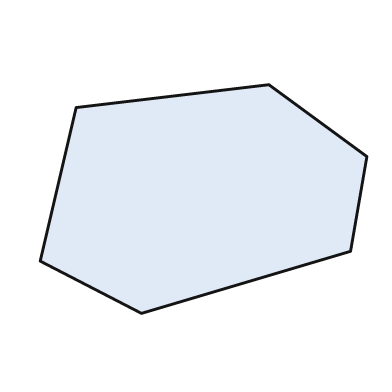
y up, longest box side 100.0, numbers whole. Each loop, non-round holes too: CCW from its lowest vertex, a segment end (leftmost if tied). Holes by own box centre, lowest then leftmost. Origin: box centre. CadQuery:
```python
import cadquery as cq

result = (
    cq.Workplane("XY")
    .moveTo(-19.0, -35.0)
    .lineTo(45.0, -16.0)
    .lineTo(50.0, 13.0)
    .lineTo(20.0, 35.0)
    .lineTo(-39.0, 28.0)
    .lineTo(-50.0, -19.0)
    .close()
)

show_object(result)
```